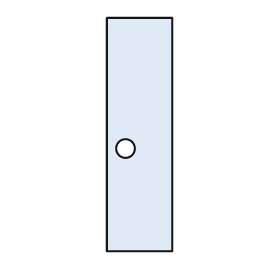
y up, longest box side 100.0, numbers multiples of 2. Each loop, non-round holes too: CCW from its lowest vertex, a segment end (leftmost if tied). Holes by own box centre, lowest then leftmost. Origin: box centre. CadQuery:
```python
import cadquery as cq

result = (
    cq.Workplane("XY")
    .moveTo(-14.0, -50.0)
    .lineTo(14.0, -50.0)
    .lineTo(14.0, 50.0)
    .lineTo(-14.0, 50.0)
    .close()
    .moveTo(-6.0, -6.0)
    .circle(4.0)
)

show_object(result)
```